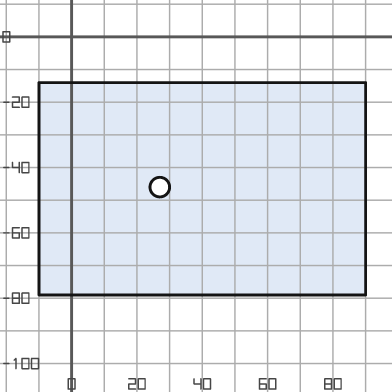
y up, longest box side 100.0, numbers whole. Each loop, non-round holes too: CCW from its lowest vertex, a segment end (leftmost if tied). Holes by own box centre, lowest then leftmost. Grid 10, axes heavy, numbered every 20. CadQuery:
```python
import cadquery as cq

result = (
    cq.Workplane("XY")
    .moveTo(-10.0, -79.0)
    .lineTo(90.0, -79.0)
    .lineTo(90.0, -14.0)
    .lineTo(-10.0, -14.0)
    .close()
    .moveTo(27.0, -46.0)
    .circle(3.0)
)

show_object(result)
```